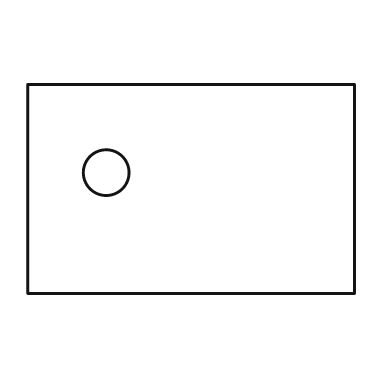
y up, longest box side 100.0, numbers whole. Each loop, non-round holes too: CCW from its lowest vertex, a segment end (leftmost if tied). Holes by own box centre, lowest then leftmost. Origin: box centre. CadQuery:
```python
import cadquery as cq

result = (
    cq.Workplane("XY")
    .moveTo(-50.0, -32.0)
    .lineTo(50.0, -32.0)
    .lineTo(50.0, 32.0)
    .lineTo(-50.0, 32.0)
    .close()
    .moveTo(-26.0, 5.0)
    .circle(7.0)
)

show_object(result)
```